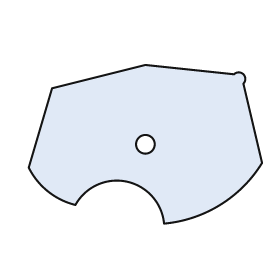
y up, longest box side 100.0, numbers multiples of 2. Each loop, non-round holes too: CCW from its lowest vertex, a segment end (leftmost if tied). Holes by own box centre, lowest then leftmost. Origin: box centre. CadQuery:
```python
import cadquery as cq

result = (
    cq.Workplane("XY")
    .moveTo(8.0, -34.0)
    .threePointArc((32.0, -26.0), (50.0, -8.0))
    .lineTo(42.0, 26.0)
    .threePointArc((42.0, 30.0), (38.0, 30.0))
    .lineTo(0.0, 34.0)
    .lineTo(-40.0, 24.0)
    .lineTo(-50.0, -10.0)
    .threePointArc((-42.0, -20.0), (-30.0, -26.0))
    .threePointArc((-8.0, -16.0), (8.0, -34.0))
    .close()
    .moveTo(0.0, 0.0)
    .circle(4.0)
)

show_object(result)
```